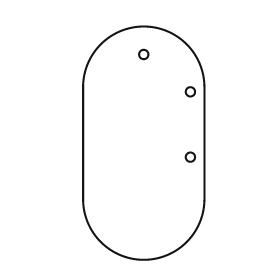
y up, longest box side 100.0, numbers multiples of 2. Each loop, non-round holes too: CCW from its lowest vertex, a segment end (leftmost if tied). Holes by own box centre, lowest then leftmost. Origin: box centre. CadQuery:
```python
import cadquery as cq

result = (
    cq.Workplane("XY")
    .moveTo(-26.0, -24.0)
    .threePointArc((0.0, -50.0), (26.0, -24.0))
    .lineTo(26.0, 24.0)
    .threePointArc((0.0, 50.0), (-26.0, 24.0))
    .close()
    .moveTo(20.0, -6.0)
    .circle(2.0)
    .moveTo(20.0, 22.0)
    .circle(2.0)
    .moveTo(0.0, 38.0)
    .circle(2.0)
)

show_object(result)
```